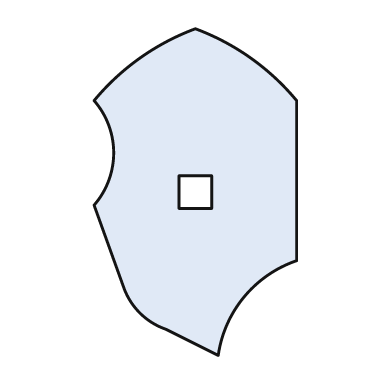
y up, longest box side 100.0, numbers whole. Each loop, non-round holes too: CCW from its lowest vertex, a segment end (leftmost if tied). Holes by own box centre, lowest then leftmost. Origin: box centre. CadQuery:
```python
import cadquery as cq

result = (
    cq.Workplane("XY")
    .moveTo(7.0, -50.0)
    .threePointArc((15.0, -32.0), (31.0, -21.0))
    .lineTo(31.0, 28.0)
    .threePointArc((17.0, 41.0), (0.0, 50.0))
    .threePointArc((-17.0, 41.0), (-31.0, 28.0))
    .threePointArc((-25.0, 12.0), (-31.0, -4.0))
    .lineTo(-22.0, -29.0)
    .threePointArc((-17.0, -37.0), (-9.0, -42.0))
    .close()
    .moveTo(-5.0, -5.0)
    .lineTo(5.0, -5.0)
    .lineTo(5.0, 5.0)
    .lineTo(-5.0, 5.0)
    .close()
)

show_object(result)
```